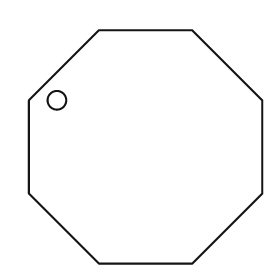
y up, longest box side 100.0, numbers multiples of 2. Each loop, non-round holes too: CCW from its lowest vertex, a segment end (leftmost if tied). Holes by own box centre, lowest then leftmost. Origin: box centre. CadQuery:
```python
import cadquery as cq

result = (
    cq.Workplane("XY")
    .moveTo(-20.0, -50.0)
    .lineTo(20.0, -50.0)
    .lineTo(50.0, -20.0)
    .lineTo(50.0, 20.0)
    .lineTo(20.0, 50.0)
    .lineTo(-20.0, 50.0)
    .lineTo(-50.0, 20.0)
    .lineTo(-50.0, -20.0)
    .close()
    .moveTo(-38.0, 20.0)
    .circle(4.0)
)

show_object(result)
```